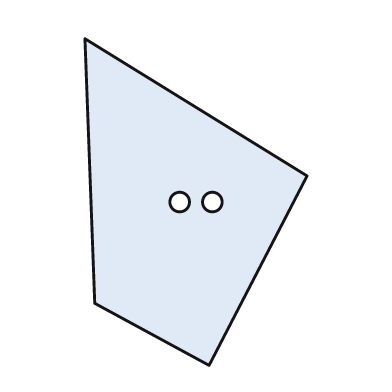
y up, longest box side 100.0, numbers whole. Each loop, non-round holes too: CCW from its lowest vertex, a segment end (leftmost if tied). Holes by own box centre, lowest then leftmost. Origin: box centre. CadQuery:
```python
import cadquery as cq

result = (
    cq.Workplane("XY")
    .moveTo(4.0, -50.0)
    .lineTo(34.0, 8.0)
    .lineTo(-34.0, 50.0)
    .lineTo(-31.0, -31.0)
    .close()
    .moveTo(-5.0, 0.0)
    .circle(3.0)
    .moveTo(5.0, 0.0)
    .circle(3.0)
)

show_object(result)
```